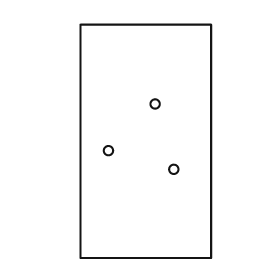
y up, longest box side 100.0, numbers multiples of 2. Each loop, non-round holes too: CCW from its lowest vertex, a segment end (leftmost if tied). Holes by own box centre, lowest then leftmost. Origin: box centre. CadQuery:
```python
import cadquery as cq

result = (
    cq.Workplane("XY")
    .moveTo(-28.0, -50.0)
    .lineTo(28.0, -50.0)
    .lineTo(28.0, 50.0)
    .lineTo(-28.0, 50.0)
    .close()
    .moveTo(12.0, -12.0)
    .circle(2.0)
    .moveTo(-16.0, -4.0)
    .circle(2.0)
    .moveTo(4.0, 16.0)
    .circle(2.0)
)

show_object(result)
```